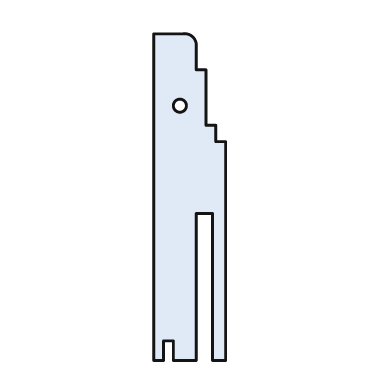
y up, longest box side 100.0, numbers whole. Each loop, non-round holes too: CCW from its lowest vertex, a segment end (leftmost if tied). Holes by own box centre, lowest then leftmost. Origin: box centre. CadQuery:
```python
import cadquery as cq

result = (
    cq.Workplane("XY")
    .moveTo(-11.0, -50.0)
    .lineTo(-8.0, -50.0)
    .lineTo(-8.0, -44.0)
    .lineTo(-5.0, -44.0)
    .lineTo(-5.0, -50.0)
    .lineTo(2.0, -50.0)
    .lineTo(2.0, -5.0)
    .lineTo(7.0, -5.0)
    .lineTo(7.0, -50.0)
    .lineTo(11.0, -50.0)
    .lineTo(11.0, 17.0)
    .lineTo(8.0, 17.0)
    .lineTo(8.0, 22.0)
    .lineTo(5.0, 22.0)
    .lineTo(5.0, 39.0)
    .lineTo(2.0, 39.0)
    .lineTo(2.0, 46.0)
    .threePointArc((1.0, 49.0), (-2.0, 50.0))
    .lineTo(-11.0, 50.0)
    .close()
    .moveTo(-3.0, 28.0)
    .circle(2.0)
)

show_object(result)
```